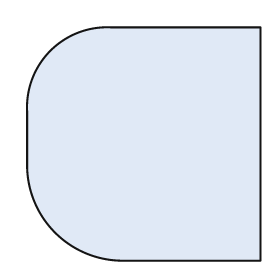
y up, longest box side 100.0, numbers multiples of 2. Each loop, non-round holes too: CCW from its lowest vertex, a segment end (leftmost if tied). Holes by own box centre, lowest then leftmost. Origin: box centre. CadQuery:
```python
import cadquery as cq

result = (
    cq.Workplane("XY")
    .moveTo(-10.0, -50.0)
    .lineTo(50.0, -50.0)
    .lineTo(50.0, 50.0)
    .lineTo(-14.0, 50.0)
    .threePointArc((-40.0, 40.0), (-50.0, 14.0))
    .lineTo(-50.0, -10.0)
    .threePointArc((-38.0, -38.0), (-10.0, -50.0))
    .close()
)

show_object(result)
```